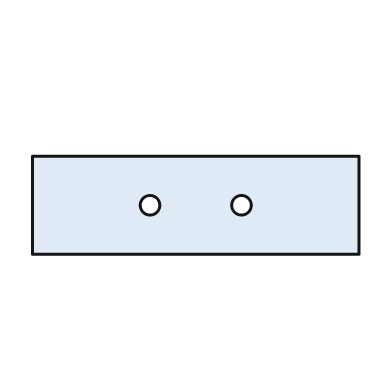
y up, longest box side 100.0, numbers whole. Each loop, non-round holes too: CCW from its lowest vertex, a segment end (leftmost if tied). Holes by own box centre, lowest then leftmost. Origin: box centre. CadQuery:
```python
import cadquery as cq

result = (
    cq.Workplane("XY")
    .moveTo(-50.0, -15.0)
    .lineTo(50.0, -15.0)
    .lineTo(50.0, 15.0)
    .lineTo(-50.0, 15.0)
    .close()
    .moveTo(-14.0, 0.0)
    .circle(3.0)
    .moveTo(14.0, 0.0)
    .circle(3.0)
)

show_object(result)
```